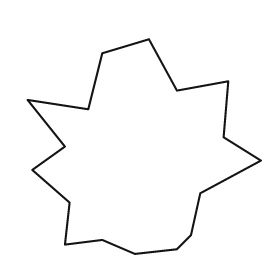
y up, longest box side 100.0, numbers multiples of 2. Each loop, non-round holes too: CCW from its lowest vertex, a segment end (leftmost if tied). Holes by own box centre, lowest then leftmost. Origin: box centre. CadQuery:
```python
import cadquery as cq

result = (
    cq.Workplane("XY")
    .moveTo(-4.0, -46.0)
    .lineTo(14.0, -44.0)
    .lineTo(20.0, -38.0)
    .lineTo(24.0, -20.0)
    .lineTo(50.0, -6.0)
    .lineTo(34.0, 4.0)
    .lineTo(36.0, 28.0)
    .lineTo(14.0, 24.0)
    .lineTo(2.0, 46.0)
    .lineTo(-18.0, 40.0)
    .lineTo(-24.0, 16.0)
    .lineTo(-50.0, 20.0)
    .lineTo(-34.0, 0.0)
    .lineTo(-48.0, -10.0)
    .lineTo(-32.0, -24.0)
    .lineTo(-34.0, -42.0)
    .lineTo(-18.0, -40.0)
    .close()
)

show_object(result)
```